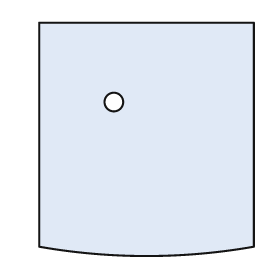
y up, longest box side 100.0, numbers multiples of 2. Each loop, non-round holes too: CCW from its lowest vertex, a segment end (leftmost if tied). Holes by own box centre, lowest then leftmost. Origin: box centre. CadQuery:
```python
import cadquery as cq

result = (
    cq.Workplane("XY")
    .moveTo(-46.0, -46.0)
    .threePointArc((0.0, -50.0), (46.0, -46.0))
    .lineTo(46.0, 50.0)
    .lineTo(-46.0, 50.0)
    .close()
    .moveTo(-14.0, 16.0)
    .circle(4.0)
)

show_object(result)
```